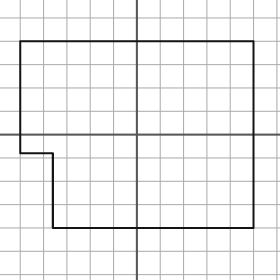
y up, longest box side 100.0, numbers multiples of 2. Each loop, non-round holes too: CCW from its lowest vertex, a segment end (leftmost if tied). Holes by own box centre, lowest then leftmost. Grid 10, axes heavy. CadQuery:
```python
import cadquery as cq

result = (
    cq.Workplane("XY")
    .moveTo(-36.0, -40.0)
    .lineTo(50.0, -40.0)
    .lineTo(50.0, 40.0)
    .lineTo(-50.0, 40.0)
    .lineTo(-50.0, -8.0)
    .lineTo(-36.0, -8.0)
    .close()
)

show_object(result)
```